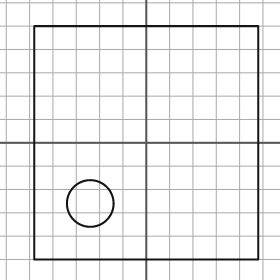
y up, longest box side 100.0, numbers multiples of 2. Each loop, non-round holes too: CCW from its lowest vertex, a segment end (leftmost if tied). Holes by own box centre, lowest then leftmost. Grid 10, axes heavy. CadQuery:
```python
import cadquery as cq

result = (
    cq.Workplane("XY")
    .moveTo(-48.0, -50.0)
    .lineTo(48.0, -50.0)
    .lineTo(48.0, 50.0)
    .lineTo(-48.0, 50.0)
    .close()
    .moveTo(-24.0, -26.0)
    .circle(10.0)
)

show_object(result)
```